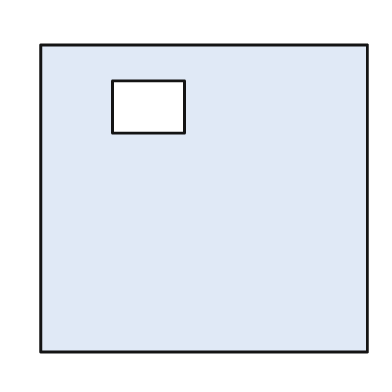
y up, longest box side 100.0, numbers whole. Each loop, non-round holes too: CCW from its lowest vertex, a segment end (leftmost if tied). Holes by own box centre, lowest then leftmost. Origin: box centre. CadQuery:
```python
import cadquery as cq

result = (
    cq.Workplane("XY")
    .moveTo(-50.0, -47.0)
    .lineTo(50.0, -47.0)
    .lineTo(50.0, 47.0)
    .lineTo(-50.0, 47.0)
    .close()
    .moveTo(-28.0, 20.0)
    .lineTo(-6.0, 20.0)
    .lineTo(-6.0, 36.0)
    .lineTo(-28.0, 36.0)
    .close()
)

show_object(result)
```